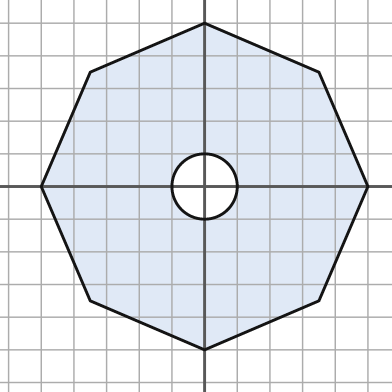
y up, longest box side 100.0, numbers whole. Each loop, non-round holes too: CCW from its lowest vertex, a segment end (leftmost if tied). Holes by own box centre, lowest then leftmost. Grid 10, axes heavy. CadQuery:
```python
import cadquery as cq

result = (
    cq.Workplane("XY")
    .moveTo(0.0, -50.0)
    .lineTo(35.0, -35.0)
    .lineTo(50.0, 0.0)
    .lineTo(35.0, 35.0)
    .lineTo(0.0, 50.0)
    .lineTo(-35.0, 35.0)
    .lineTo(-50.0, 0.0)
    .lineTo(-35.0, -35.0)
    .close()
    .moveTo(0.0, 0.0)
    .circle(10.0)
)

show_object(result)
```